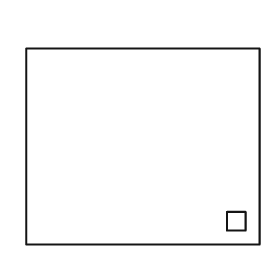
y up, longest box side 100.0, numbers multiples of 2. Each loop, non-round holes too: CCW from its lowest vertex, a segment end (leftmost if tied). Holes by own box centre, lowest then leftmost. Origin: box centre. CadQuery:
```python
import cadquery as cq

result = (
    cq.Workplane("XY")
    .moveTo(-50.0, -42.0)
    .lineTo(50.0, -42.0)
    .lineTo(50.0, 42.0)
    .lineTo(-50.0, 42.0)
    .close()
    .moveTo(36.0, -36.0)
    .lineTo(44.0, -36.0)
    .lineTo(44.0, -28.0)
    .lineTo(36.0, -28.0)
    .close()
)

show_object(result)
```